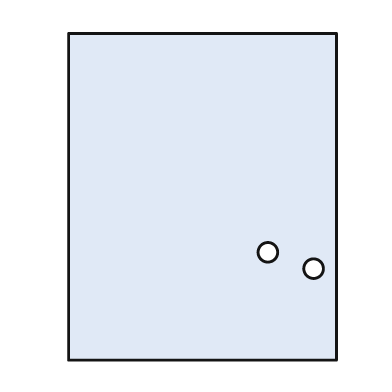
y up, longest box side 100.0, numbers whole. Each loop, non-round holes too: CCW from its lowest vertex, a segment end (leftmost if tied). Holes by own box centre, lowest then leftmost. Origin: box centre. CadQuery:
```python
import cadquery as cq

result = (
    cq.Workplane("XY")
    .moveTo(-41.0, -50.0)
    .lineTo(41.0, -50.0)
    .lineTo(41.0, 50.0)
    .lineTo(-41.0, 50.0)
    .close()
    .moveTo(34.0, -22.0)
    .circle(3.0)
    .moveTo(20.0, -17.0)
    .circle(3.0)
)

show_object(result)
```